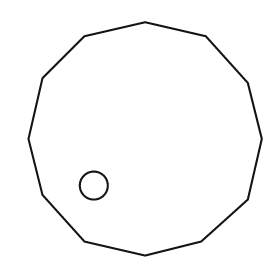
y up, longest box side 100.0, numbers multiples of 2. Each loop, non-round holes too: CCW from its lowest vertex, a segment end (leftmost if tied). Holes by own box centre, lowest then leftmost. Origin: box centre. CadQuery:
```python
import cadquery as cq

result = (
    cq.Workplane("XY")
    .moveTo(0.0, -50.0)
    .lineTo(24.0, -44.0)
    .lineTo(44.0, -26.0)
    .lineTo(50.0, 0.0)
    .lineTo(44.0, 24.0)
    .lineTo(26.0, 44.0)
    .lineTo(0.0, 50.0)
    .lineTo(-26.0, 44.0)
    .lineTo(-44.0, 26.0)
    .lineTo(-50.0, 0.0)
    .lineTo(-44.0, -24.0)
    .lineTo(-26.0, -44.0)
    .close()
    .moveTo(-22.0, -20.0)
    .circle(6.0)
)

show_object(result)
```